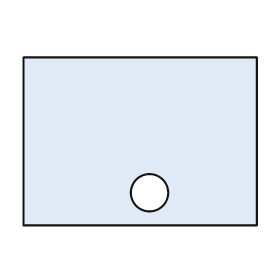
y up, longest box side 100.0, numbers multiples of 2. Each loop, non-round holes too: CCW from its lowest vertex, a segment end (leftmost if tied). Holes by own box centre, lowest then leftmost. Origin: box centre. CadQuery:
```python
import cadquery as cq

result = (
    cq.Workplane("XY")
    .moveTo(-50.0, -36.0)
    .lineTo(50.0, -36.0)
    .lineTo(50.0, 36.0)
    .lineTo(-50.0, 36.0)
    .close()
    .moveTo(4.0, -22.0)
    .circle(8.0)
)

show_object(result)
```